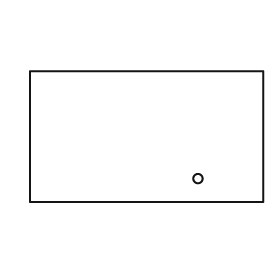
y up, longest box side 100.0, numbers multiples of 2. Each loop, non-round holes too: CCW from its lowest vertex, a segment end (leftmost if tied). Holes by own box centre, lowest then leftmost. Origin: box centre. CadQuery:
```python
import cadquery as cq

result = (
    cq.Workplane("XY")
    .moveTo(-50.0, -28.0)
    .lineTo(50.0, -28.0)
    .lineTo(50.0, 28.0)
    .lineTo(-50.0, 28.0)
    .close()
    .moveTo(22.0, -18.0)
    .circle(2.0)
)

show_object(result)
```